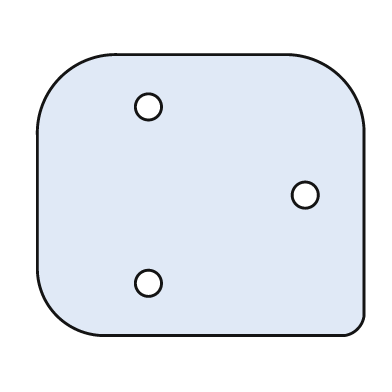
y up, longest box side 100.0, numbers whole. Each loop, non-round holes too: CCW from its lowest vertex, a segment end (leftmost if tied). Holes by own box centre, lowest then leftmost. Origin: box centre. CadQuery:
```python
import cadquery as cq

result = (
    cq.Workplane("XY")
    .moveTo(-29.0, -43.0)
    .lineTo(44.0, -43.0)
    .threePointArc((48.0, -41.0), (50.0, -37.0))
    .lineTo(50.0, 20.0)
    .threePointArc((43.0, 36.0), (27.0, 43.0))
    .lineTo(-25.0, 43.0)
    .threePointArc((-43.0, 36.0), (-50.0, 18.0))
    .lineTo(-50.0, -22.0)
    .threePointArc((-44.0, -37.0), (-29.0, -43.0))
    .close()
    .moveTo(-16.0, -27.0)
    .circle(4.0)
    .moveTo(32.0, 0.0)
    .circle(4.0)
    .moveTo(-16.0, 27.0)
    .circle(4.0)
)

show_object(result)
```